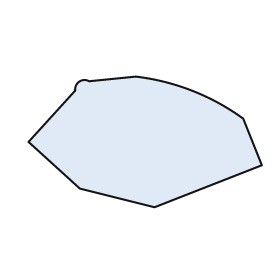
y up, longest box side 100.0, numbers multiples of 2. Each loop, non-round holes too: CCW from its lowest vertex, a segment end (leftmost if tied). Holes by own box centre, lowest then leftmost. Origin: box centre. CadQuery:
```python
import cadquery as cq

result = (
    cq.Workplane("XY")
    .moveTo(4.0, -28.0)
    .lineTo(50.0, -10.0)
    .lineTo(42.0, 10.0)
    .threePointArc((20.0, 22.0), (-4.0, 28.0))
    .lineTo(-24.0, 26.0)
    .threePointArc((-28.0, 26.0), (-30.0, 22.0))
    .lineTo(-50.0, 0.0)
    .lineTo(-28.0, -20.0)
    .close()
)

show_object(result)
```